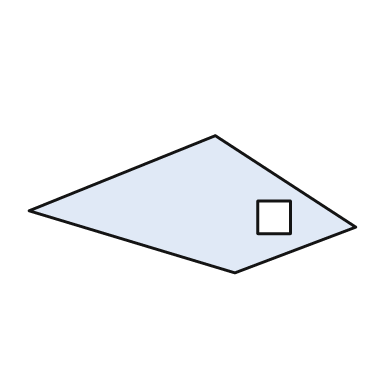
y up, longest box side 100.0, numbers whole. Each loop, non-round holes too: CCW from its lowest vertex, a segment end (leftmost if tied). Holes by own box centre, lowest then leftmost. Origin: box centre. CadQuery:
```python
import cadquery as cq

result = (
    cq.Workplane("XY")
    .moveTo(13.0, -21.0)
    .lineTo(50.0, -7.0)
    .lineTo(7.0, 21.0)
    .lineTo(-50.0, -2.0)
    .close()
    .moveTo(20.0, -9.0)
    .lineTo(30.0, -9.0)
    .lineTo(30.0, 1.0)
    .lineTo(20.0, 1.0)
    .close()
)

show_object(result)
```